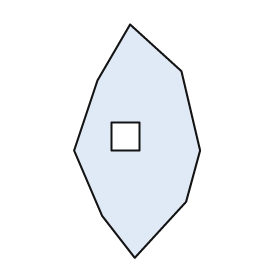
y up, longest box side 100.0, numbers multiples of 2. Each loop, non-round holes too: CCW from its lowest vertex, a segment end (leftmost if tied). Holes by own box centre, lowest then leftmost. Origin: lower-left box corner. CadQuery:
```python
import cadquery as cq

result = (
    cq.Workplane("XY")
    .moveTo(26.0, 0.0)
    .lineTo(48.0, 24.0)
    .lineTo(54.0, 46.0)
    .lineTo(46.0, 80.0)
    .lineTo(24.0, 100.0)
    .lineTo(10.0, 76.0)
    .lineTo(0.0, 46.0)
    .lineTo(12.0, 18.0)
    .close()
    .moveTo(16.0, 46.0)
    .lineTo(28.0, 46.0)
    .lineTo(28.0, 58.0)
    .lineTo(16.0, 58.0)
    .close()
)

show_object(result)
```